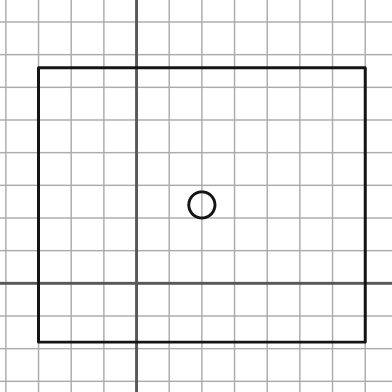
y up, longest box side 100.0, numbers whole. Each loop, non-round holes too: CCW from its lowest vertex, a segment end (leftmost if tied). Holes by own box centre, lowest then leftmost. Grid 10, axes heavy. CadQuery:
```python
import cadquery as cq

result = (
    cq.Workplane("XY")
    .moveTo(-30.0, -18.0)
    .lineTo(70.0, -18.0)
    .lineTo(70.0, 66.0)
    .lineTo(-30.0, 66.0)
    .close()
    .moveTo(20.0, 24.0)
    .circle(4.0)
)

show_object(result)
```